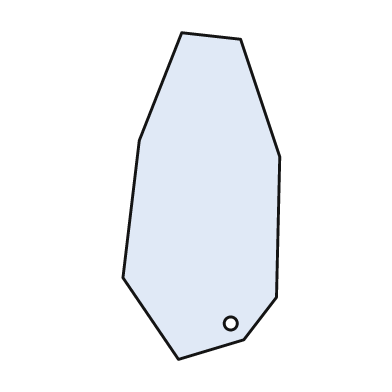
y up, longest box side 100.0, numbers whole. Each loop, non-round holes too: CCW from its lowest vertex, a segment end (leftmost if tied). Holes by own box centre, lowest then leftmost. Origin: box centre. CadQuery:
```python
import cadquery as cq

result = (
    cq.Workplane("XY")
    .moveTo(-7.0, -50.0)
    .lineTo(13.0, -44.0)
    .lineTo(23.0, -31.0)
    .lineTo(24.0, 12.0)
    .lineTo(12.0, 48.0)
    .lineTo(-6.0, 50.0)
    .lineTo(-19.0, 17.0)
    .lineTo(-24.0, -25.0)
    .close()
    .moveTo(9.0, -39.0)
    .circle(2.0)
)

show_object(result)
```